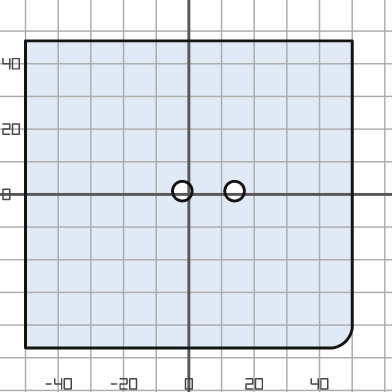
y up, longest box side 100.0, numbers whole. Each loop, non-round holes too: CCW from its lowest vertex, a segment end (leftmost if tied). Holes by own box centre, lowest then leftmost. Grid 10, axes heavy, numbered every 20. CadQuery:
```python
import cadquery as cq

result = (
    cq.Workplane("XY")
    .moveTo(-50.0, -47.0)
    .lineTo(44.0, -47.0)
    .threePointArc((48.0, -45.0), (50.0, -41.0))
    .lineTo(50.0, 47.0)
    .lineTo(-50.0, 47.0)
    .close()
    .moveTo(-2.0, 1.0)
    .circle(3.0)
    .moveTo(14.0, 1.0)
    .circle(3.0)
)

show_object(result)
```